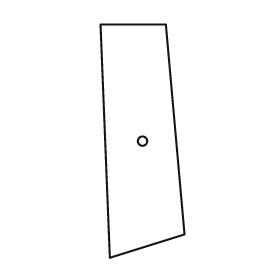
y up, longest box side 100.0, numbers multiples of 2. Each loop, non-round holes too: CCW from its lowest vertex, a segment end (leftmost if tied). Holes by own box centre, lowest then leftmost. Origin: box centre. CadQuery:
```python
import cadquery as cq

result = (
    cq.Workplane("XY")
    .moveTo(-14.0, -50.0)
    .lineTo(18.0, -40.0)
    .lineTo(10.0, 50.0)
    .lineTo(-18.0, 50.0)
    .close()
    .moveTo(0.0, 0.0)
    .circle(2.0)
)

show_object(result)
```